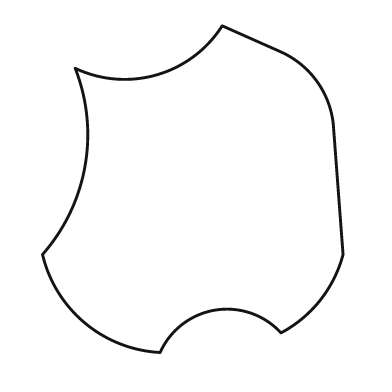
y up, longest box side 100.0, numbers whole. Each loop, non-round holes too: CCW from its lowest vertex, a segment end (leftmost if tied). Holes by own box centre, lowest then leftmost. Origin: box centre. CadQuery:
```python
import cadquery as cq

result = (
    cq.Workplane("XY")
    .moveTo(-10.0, -50.0)
    .threePointArc((7.0, -37.0), (27.0, -44.0))
    .threePointArc((39.0, -34.0), (46.0, -20.0))
    .lineTo(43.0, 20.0)
    .threePointArc((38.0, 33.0), (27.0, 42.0))
    .lineTo(9.0, 50.0)
    .threePointArc((-11.0, 35.0), (-36.0, 37.0))
    .threePointArc((-33.0, 7.0), (-46.0, -20.0))
    .threePointArc((-33.0, -41.0), (-10.0, -50.0))
    .close()
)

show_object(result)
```